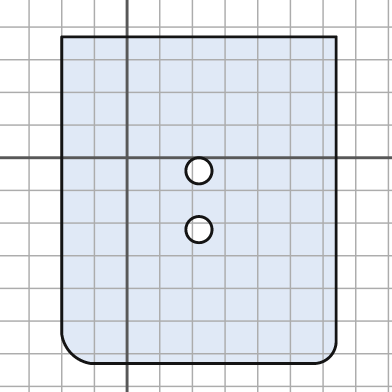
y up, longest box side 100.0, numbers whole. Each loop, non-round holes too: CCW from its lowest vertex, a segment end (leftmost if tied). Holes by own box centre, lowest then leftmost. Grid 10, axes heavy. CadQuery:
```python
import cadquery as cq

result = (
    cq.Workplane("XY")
    .moveTo(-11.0, -63.0)
    .lineTo(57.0, -63.0)
    .threePointArc((62.0, -61.0), (64.0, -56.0))
    .lineTo(64.0, 37.0)
    .lineTo(-20.0, 37.0)
    .lineTo(-20.0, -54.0)
    .threePointArc((-17.0, -60.0), (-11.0, -63.0))
    .close()
    .moveTo(22.0, -22.0)
    .circle(4.0)
    .moveTo(22.0, -4.0)
    .circle(4.0)
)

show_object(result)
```